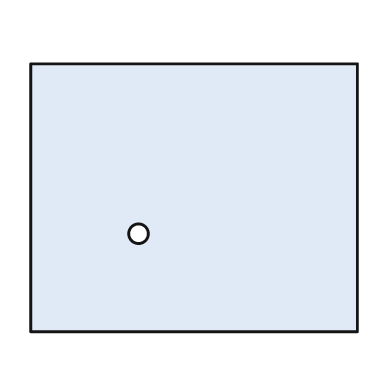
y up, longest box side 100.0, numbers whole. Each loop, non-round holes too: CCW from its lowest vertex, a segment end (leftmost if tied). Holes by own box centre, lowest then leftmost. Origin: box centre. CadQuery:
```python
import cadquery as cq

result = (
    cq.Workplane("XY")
    .moveTo(-50.0, -41.0)
    .lineTo(50.0, -41.0)
    .lineTo(50.0, 41.0)
    .lineTo(-50.0, 41.0)
    .close()
    .moveTo(-17.0, -11.0)
    .circle(3.0)
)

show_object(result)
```